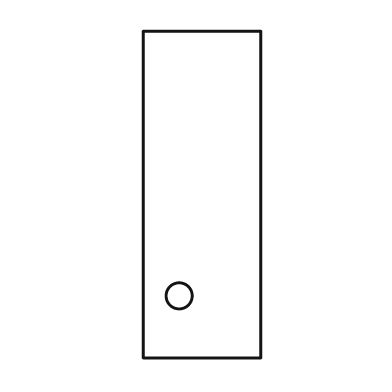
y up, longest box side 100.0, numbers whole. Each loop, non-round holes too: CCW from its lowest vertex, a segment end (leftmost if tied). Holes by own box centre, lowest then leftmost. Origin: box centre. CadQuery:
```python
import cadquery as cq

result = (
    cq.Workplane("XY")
    .moveTo(-18.0, -50.0)
    .lineTo(18.0, -50.0)
    .lineTo(18.0, 50.0)
    .lineTo(-18.0, 50.0)
    .close()
    .moveTo(-7.0, -31.0)
    .circle(4.0)
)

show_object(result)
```